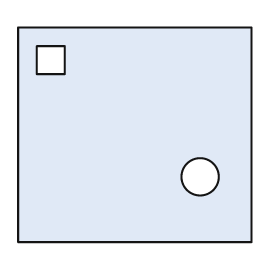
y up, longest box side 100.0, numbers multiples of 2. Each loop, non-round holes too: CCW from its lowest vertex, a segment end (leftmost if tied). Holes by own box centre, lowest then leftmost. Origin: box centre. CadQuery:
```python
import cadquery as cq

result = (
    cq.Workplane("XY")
    .moveTo(-50.0, -46.0)
    .lineTo(50.0, -46.0)
    .lineTo(50.0, 46.0)
    .lineTo(-50.0, 46.0)
    .close()
    .moveTo(28.0, -18.0)
    .circle(8.0)
    .moveTo(-42.0, 26.0)
    .lineTo(-30.0, 26.0)
    .lineTo(-30.0, 38.0)
    .lineTo(-42.0, 38.0)
    .close()
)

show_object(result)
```